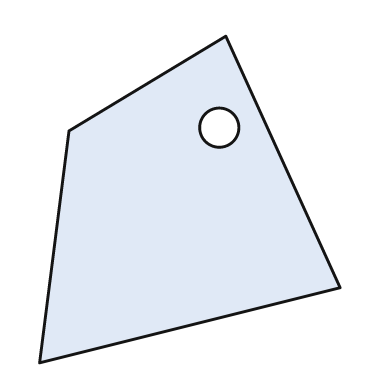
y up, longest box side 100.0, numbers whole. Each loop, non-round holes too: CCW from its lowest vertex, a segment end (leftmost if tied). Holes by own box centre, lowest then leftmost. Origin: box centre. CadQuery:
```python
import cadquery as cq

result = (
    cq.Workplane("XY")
    .moveTo(-46.0, -50.0)
    .lineTo(46.0, -27.0)
    .lineTo(11.0, 50.0)
    .lineTo(-37.0, 21.0)
    .close()
    .moveTo(9.0, 22.0)
    .circle(6.0)
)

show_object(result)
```